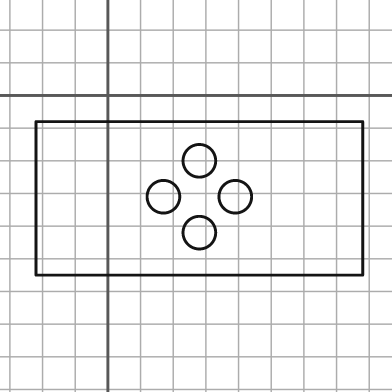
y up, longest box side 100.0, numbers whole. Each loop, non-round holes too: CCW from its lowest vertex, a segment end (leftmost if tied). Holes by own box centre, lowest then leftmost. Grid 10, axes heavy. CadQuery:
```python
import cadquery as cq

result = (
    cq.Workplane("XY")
    .moveTo(-22.0, -55.0)
    .lineTo(78.0, -55.0)
    .lineTo(78.0, -8.0)
    .lineTo(-22.0, -8.0)
    .close()
    .moveTo(28.0, -42.0)
    .circle(5.0)
    .moveTo(17.0, -31.0)
    .circle(5.0)
    .moveTo(39.0, -31.0)
    .circle(5.0)
    .moveTo(28.0, -20.0)
    .circle(5.0)
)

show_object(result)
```